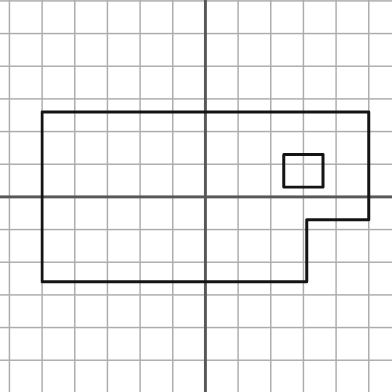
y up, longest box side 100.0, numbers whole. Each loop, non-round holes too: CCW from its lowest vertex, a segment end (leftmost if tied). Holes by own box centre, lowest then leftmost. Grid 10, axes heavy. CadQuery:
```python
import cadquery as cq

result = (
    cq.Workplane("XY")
    .moveTo(-50.0, -26.0)
    .lineTo(31.0, -26.0)
    .lineTo(31.0, -7.0)
    .lineTo(50.0, -7.0)
    .lineTo(50.0, 26.0)
    .lineTo(-50.0, 26.0)
    .close()
    .moveTo(24.0, 3.0)
    .lineTo(36.0, 3.0)
    .lineTo(36.0, 13.0)
    .lineTo(24.0, 13.0)
    .close()
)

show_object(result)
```